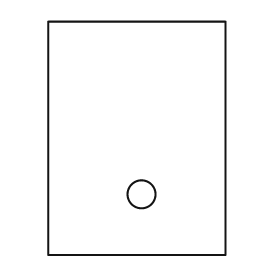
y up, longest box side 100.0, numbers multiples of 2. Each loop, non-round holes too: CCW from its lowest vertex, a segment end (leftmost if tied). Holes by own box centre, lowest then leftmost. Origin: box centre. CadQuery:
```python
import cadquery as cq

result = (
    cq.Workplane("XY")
    .moveTo(-38.0, -50.0)
    .lineTo(38.0, -50.0)
    .lineTo(38.0, 50.0)
    .lineTo(-38.0, 50.0)
    .close()
    .moveTo(2.0, -24.0)
    .circle(6.0)
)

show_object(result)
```